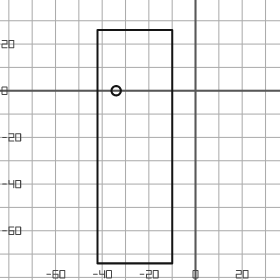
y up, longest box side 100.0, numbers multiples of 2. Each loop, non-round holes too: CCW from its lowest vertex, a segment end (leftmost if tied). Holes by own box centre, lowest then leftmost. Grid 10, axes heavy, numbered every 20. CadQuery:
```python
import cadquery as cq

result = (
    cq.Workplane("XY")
    .moveTo(-42.0, -74.0)
    .lineTo(-10.0, -74.0)
    .lineTo(-10.0, 26.0)
    .lineTo(-42.0, 26.0)
    .close()
    .moveTo(-34.0, 0.0)
    .circle(2.0)
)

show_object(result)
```